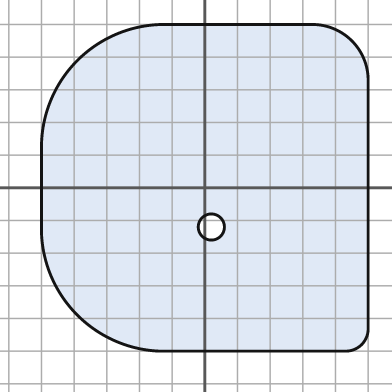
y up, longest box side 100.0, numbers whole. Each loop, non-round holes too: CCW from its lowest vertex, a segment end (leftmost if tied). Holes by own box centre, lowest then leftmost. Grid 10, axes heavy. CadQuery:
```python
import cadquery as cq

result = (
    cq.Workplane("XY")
    .moveTo(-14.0, -50.0)
    .lineTo(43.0, -50.0)
    .threePointArc((48.0, -48.0), (50.0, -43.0))
    .lineTo(50.0, 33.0)
    .threePointArc((45.0, 45.0), (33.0, 50.0))
    .lineTo(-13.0, 50.0)
    .threePointArc((-39.0, 39.0), (-50.0, 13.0))
    .lineTo(-50.0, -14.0)
    .threePointArc((-39.0, -39.0), (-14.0, -50.0))
    .close()
    .moveTo(2.0, -12.0)
    .circle(4.0)
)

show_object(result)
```